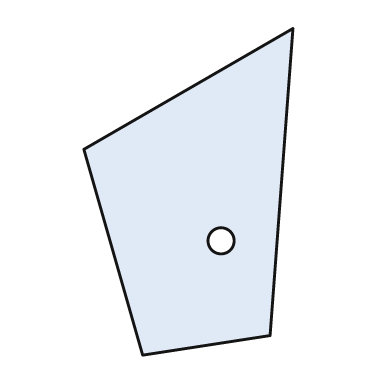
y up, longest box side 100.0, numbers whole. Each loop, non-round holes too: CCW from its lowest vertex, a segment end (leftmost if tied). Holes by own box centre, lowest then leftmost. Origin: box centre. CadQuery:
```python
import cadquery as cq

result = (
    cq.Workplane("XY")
    .moveTo(-14.0, -50.0)
    .lineTo(25.0, -44.0)
    .lineTo(32.0, 50.0)
    .lineTo(-32.0, 13.0)
    .close()
    .moveTo(10.0, -15.0)
    .circle(4.0)
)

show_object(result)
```